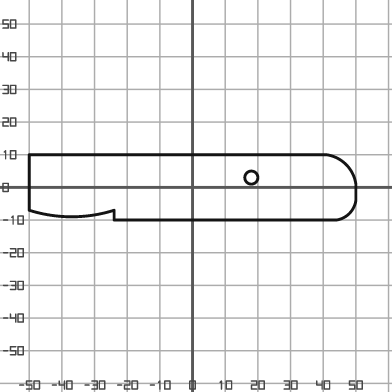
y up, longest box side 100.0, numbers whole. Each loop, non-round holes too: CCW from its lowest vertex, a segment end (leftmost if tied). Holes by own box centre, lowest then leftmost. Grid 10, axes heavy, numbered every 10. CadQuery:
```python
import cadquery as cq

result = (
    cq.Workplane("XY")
    .moveTo(-24.0, -10.0)
    .lineTo(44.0, -10.0)
    .threePointArc((48.0, -8.0), (50.0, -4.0))
    .lineTo(50.0, 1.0)
    .threePointArc((47.0, 7.0), (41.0, 10.0))
    .lineTo(-50.0, 10.0)
    .lineTo(-50.0, -7.0)
    .threePointArc((-37.0, -9.0), (-24.0, -7.0))
    .close()
    .moveTo(18.0, 3.0)
    .circle(2.0)
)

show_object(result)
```